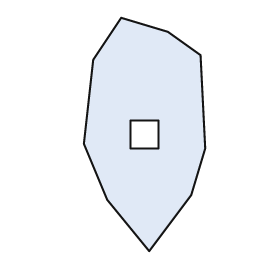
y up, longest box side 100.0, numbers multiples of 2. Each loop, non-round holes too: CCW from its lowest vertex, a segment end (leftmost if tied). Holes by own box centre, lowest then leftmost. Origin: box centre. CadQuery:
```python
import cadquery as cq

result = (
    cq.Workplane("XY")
    .moveTo(2.0, -50.0)
    .lineTo(20.0, -26.0)
    .lineTo(26.0, -6.0)
    .lineTo(24.0, 34.0)
    .lineTo(10.0, 44.0)
    .lineTo(-10.0, 50.0)
    .lineTo(-22.0, 32.0)
    .lineTo(-26.0, -4.0)
    .lineTo(-16.0, -28.0)
    .close()
    .moveTo(-6.0, -6.0)
    .lineTo(6.0, -6.0)
    .lineTo(6.0, 6.0)
    .lineTo(-6.0, 6.0)
    .close()
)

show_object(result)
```